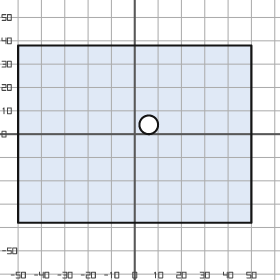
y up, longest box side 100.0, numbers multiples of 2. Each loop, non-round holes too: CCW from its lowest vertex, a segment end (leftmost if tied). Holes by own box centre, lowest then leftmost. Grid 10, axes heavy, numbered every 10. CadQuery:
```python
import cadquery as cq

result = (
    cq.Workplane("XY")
    .moveTo(-50.0, -38.0)
    .lineTo(50.0, -38.0)
    .lineTo(50.0, 38.0)
    .lineTo(-50.0, 38.0)
    .close()
    .moveTo(6.0, 4.0)
    .circle(4.0)
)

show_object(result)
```